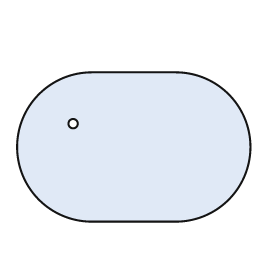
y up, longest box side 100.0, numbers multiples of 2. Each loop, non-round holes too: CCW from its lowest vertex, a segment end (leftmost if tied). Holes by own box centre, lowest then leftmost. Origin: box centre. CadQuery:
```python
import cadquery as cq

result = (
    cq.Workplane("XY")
    .moveTo(-18.0, -32.0)
    .lineTo(18.0, -32.0)
    .threePointArc((50.0, 0.0), (18.0, 32.0))
    .lineTo(-18.0, 32.0)
    .threePointArc((-50.0, 0.0), (-18.0, -32.0))
    .close()
    .moveTo(-26.0, 10.0)
    .circle(2.0)
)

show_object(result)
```